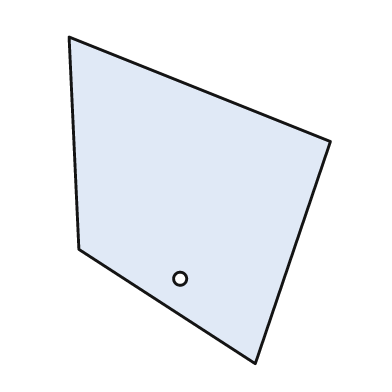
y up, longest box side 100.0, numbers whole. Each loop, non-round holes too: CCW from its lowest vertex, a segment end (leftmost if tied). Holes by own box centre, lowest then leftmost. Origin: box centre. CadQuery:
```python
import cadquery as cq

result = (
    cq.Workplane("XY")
    .moveTo(17.0, -50.0)
    .lineTo(40.0, 18.0)
    .lineTo(-40.0, 50.0)
    .lineTo(-37.0, -15.0)
    .close()
    .moveTo(-6.0, -24.0)
    .circle(2.0)
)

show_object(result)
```